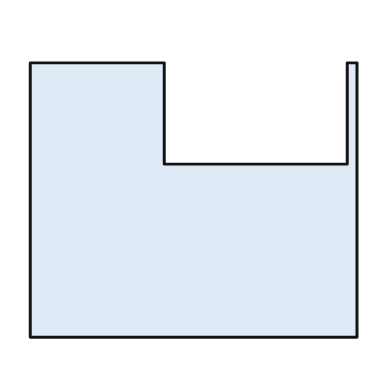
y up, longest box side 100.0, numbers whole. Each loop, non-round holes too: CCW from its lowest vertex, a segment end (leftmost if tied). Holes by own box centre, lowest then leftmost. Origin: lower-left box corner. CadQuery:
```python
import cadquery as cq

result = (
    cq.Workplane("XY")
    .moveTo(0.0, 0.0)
    .lineTo(100.0, 0.0)
    .lineTo(100.0, 84.0)
    .lineTo(97.0, 84.0)
    .lineTo(97.0, 53.0)
    .lineTo(41.0, 53.0)
    .lineTo(41.0, 84.0)
    .lineTo(0.0, 84.0)
    .close()
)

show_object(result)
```